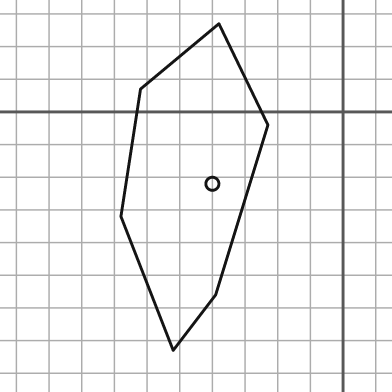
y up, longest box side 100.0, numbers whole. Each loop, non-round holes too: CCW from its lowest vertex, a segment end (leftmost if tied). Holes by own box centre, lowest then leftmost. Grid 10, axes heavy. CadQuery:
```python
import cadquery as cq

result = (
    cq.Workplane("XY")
    .moveTo(-52.0, -73.0)
    .lineTo(-39.0, -56.0)
    .lineTo(-23.0, -4.0)
    .lineTo(-38.0, 27.0)
    .lineTo(-62.0, 7.0)
    .lineTo(-68.0, -32.0)
    .close()
    .moveTo(-40.0, -22.0)
    .circle(2.0)
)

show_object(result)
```